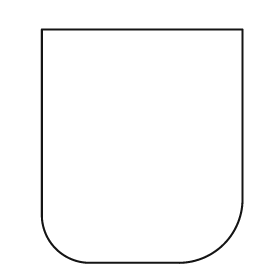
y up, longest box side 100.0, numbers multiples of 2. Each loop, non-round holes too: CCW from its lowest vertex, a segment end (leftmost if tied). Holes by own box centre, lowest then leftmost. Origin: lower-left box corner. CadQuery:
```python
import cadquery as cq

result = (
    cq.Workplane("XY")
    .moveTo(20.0, 0.0)
    .lineTo(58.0, 0.0)
    .threePointArc((78.0, 8.0), (86.0, 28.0))
    .lineTo(86.0, 100.0)
    .lineTo(0.0, 100.0)
    .lineTo(0.0, 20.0)
    .threePointArc((6.0, 6.0), (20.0, 0.0))
    .close()
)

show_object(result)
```